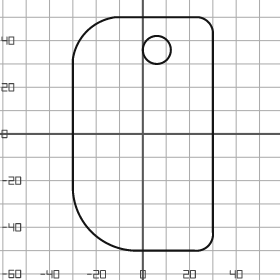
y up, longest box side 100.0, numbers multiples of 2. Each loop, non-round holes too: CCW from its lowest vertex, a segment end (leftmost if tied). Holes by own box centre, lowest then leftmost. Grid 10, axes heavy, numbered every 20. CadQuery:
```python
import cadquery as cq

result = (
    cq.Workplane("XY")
    .moveTo(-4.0, -50.0)
    .lineTo(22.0, -50.0)
    .threePointArc((28.0, -48.0), (30.0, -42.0))
    .lineTo(30.0, 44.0)
    .threePointArc((28.0, 48.0), (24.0, 50.0))
    .lineTo(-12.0, 50.0)
    .threePointArc((-24.0, 44.0), (-30.0, 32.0))
    .lineTo(-30.0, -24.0)
    .threePointArc((-22.0, -42.0), (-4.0, -50.0))
    .close()
    .moveTo(6.0, 36.0)
    .circle(6.0)
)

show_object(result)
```